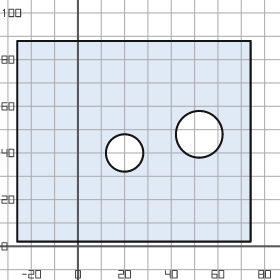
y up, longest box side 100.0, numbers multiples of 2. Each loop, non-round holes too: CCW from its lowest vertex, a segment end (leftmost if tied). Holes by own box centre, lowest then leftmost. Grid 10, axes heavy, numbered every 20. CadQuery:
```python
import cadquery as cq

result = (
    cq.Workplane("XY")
    .moveTo(-26.0, 2.0)
    .lineTo(74.0, 2.0)
    .lineTo(74.0, 88.0)
    .lineTo(-26.0, 88.0)
    .close()
    .moveTo(20.0, 40.0)
    .circle(8.0)
    .moveTo(52.0, 48.0)
    .circle(10.0)
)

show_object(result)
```